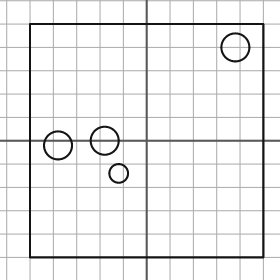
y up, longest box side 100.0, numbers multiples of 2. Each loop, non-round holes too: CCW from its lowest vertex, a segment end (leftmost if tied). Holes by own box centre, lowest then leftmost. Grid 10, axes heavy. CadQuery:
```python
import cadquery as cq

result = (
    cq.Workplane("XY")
    .moveTo(-50.0, -50.0)
    .lineTo(50.0, -50.0)
    .lineTo(50.0, 50.0)
    .lineTo(-50.0, 50.0)
    .close()
    .moveTo(-12.0, -14.0)
    .circle(4.0)
    .moveTo(-38.0, -2.0)
    .circle(6.0)
    .moveTo(-18.0, 0.0)
    .circle(6.0)
    .moveTo(38.0, 40.0)
    .circle(6.0)
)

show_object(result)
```